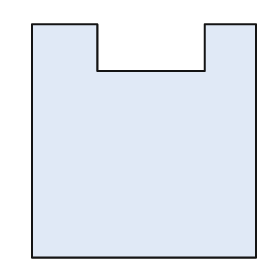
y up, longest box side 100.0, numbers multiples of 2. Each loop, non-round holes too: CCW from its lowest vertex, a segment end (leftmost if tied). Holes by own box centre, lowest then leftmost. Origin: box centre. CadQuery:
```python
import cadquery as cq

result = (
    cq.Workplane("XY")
    .moveTo(-48.0, -50.0)
    .lineTo(48.0, -50.0)
    .lineTo(48.0, 50.0)
    .lineTo(26.0, 50.0)
    .lineTo(26.0, 30.0)
    .lineTo(-20.0, 30.0)
    .lineTo(-20.0, 50.0)
    .lineTo(-48.0, 50.0)
    .close()
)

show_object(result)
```